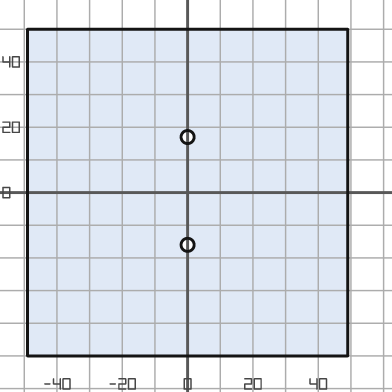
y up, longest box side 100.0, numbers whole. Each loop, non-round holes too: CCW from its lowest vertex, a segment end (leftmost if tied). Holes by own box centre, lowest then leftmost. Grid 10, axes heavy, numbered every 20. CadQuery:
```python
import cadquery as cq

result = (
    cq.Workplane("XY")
    .moveTo(-49.0, -50.0)
    .lineTo(49.0, -50.0)
    .lineTo(49.0, 50.0)
    .lineTo(-49.0, 50.0)
    .close()
    .moveTo(0.0, -16.0)
    .circle(2.0)
    .moveTo(0.0, 17.0)
    .circle(2.0)
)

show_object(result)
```